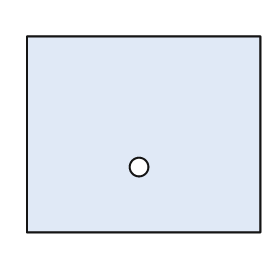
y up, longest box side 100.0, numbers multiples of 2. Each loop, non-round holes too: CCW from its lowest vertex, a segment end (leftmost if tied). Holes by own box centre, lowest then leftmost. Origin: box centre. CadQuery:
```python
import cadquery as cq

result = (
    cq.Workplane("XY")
    .moveTo(-50.0, -42.0)
    .lineTo(50.0, -42.0)
    .lineTo(50.0, 42.0)
    .lineTo(-50.0, 42.0)
    .close()
    .moveTo(-2.0, -14.0)
    .circle(4.0)
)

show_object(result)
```